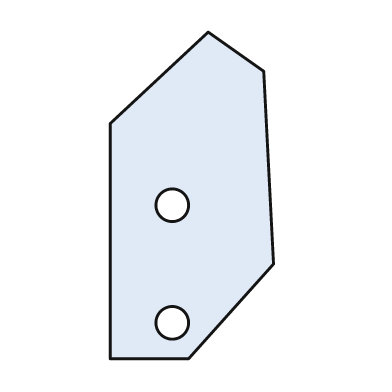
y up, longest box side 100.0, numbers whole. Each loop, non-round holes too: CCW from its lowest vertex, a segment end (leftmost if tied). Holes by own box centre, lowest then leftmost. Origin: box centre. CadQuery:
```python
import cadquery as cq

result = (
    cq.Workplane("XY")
    .moveTo(-25.0, -50.0)
    .lineTo(-1.0, -50.0)
    .lineTo(25.0, -21.0)
    .lineTo(22.0, 38.0)
    .lineTo(5.0, 50.0)
    .lineTo(-25.0, 22.0)
    .close()
    .moveTo(-6.0, -39.0)
    .circle(5.0)
    .moveTo(-6.0, -3.0)
    .circle(5.0)
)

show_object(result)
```